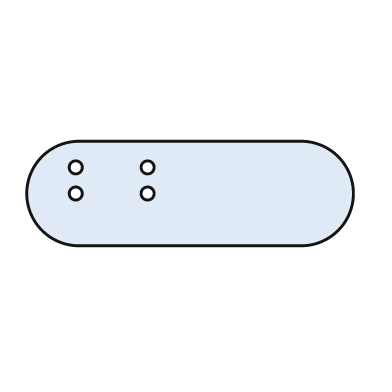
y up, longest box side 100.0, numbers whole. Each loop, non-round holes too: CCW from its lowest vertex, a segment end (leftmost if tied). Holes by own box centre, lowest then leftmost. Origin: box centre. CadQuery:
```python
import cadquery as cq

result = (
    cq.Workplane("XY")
    .moveTo(-34.0, -16.0)
    .lineTo(34.0, -16.0)
    .threePointArc((50.0, 0.0), (34.0, 16.0))
    .lineTo(-34.0, 16.0)
    .threePointArc((-50.0, 0.0), (-34.0, -16.0))
    .close()
    .moveTo(-35.0, 0.0)
    .circle(2.0)
    .moveTo(-13.0, 0.0)
    .circle(2.0)
    .moveTo(-35.0, 8.0)
    .circle(2.0)
    .moveTo(-13.0, 8.0)
    .circle(2.0)
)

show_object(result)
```